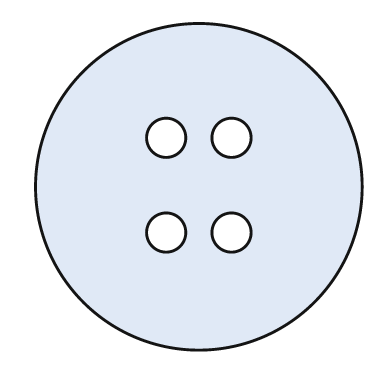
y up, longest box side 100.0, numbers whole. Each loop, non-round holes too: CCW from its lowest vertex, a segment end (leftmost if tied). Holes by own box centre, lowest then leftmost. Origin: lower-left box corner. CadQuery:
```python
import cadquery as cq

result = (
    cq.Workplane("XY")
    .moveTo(50.0, 50.0)
    .circle(50.0)
    .moveTo(40.0, 36.0)
    .circle(6.0)
    .moveTo(60.0, 36.0)
    .circle(6.0)
    .moveTo(40.0, 65.0)
    .circle(6.0)
    .moveTo(60.0, 65.0)
    .circle(6.0)
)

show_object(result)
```